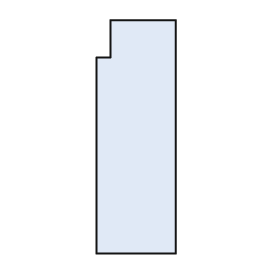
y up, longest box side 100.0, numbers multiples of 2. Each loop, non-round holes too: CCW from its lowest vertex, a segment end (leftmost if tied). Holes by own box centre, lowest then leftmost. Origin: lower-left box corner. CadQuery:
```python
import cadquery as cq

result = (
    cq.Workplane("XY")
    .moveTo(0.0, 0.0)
    .lineTo(34.0, 0.0)
    .lineTo(34.0, 100.0)
    .lineTo(6.0, 100.0)
    .lineTo(6.0, 84.0)
    .lineTo(0.0, 84.0)
    .close()
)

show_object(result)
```